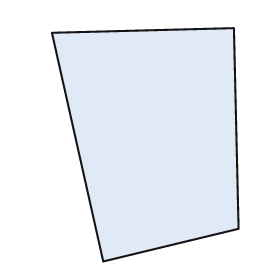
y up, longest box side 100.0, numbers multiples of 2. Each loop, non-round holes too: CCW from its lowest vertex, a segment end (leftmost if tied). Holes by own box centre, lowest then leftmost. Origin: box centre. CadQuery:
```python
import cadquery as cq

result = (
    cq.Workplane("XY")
    .moveTo(-18.0, -50.0)
    .lineTo(40.0, -36.0)
    .lineTo(38.0, 50.0)
    .lineTo(-40.0, 48.0)
    .close()
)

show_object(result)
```